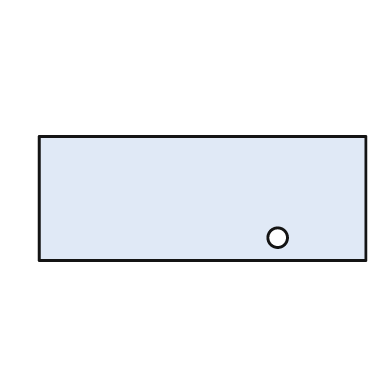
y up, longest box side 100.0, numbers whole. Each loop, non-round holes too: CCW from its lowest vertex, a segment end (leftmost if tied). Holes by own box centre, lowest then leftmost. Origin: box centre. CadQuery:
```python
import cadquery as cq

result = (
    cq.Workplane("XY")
    .moveTo(-50.0, -19.0)
    .lineTo(50.0, -19.0)
    .lineTo(50.0, 19.0)
    .lineTo(-50.0, 19.0)
    .close()
    .moveTo(23.0, -12.0)
    .circle(3.0)
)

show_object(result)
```